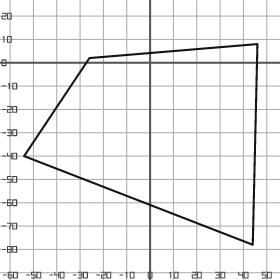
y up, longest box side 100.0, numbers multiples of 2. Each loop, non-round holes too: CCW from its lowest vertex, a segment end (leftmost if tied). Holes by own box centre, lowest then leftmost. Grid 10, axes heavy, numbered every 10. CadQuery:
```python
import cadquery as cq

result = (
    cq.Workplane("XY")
    .moveTo(44.0, -78.0)
    .lineTo(46.0, 8.0)
    .lineTo(-26.0, 2.0)
    .lineTo(-54.0, -40.0)
    .close()
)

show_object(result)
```